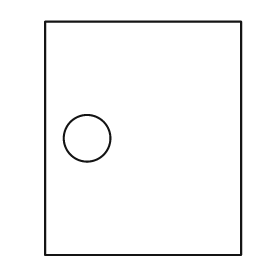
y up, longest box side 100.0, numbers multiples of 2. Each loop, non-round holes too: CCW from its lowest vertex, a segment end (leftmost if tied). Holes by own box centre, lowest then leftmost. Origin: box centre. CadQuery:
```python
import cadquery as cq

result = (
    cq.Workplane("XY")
    .moveTo(-42.0, -50.0)
    .lineTo(42.0, -50.0)
    .lineTo(42.0, 50.0)
    .lineTo(-42.0, 50.0)
    .close()
    .moveTo(-24.0, 0.0)
    .circle(10.0)
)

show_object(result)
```